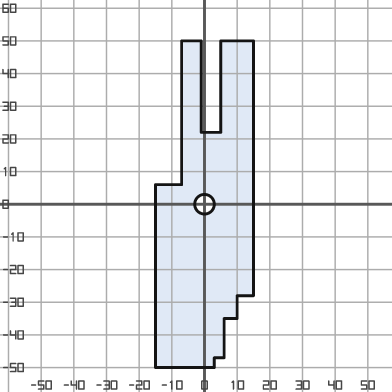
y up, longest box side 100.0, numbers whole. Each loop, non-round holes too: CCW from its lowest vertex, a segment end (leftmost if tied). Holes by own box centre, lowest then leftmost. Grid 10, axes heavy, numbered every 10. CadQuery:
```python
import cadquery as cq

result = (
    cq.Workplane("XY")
    .moveTo(-15.0, -50.0)
    .lineTo(3.0, -50.0)
    .lineTo(3.0, -47.0)
    .lineTo(6.0, -47.0)
    .lineTo(6.0, -35.0)
    .lineTo(10.0, -35.0)
    .lineTo(10.0, -28.0)
    .lineTo(15.0, -28.0)
    .lineTo(15.0, 50.0)
    .lineTo(5.0, 50.0)
    .lineTo(5.0, 22.0)
    .lineTo(-1.0, 22.0)
    .lineTo(-1.0, 50.0)
    .lineTo(-7.0, 50.0)
    .lineTo(-7.0, 6.0)
    .lineTo(-15.0, 6.0)
    .close()
    .moveTo(0.0, 0.0)
    .circle(3.0)
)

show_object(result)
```